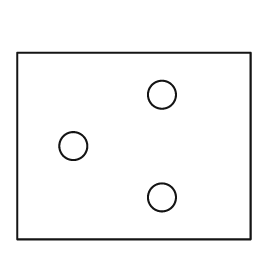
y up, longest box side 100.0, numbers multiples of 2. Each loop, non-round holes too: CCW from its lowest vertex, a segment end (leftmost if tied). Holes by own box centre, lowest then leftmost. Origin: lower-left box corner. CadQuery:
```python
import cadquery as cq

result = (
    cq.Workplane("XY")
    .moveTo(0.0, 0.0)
    .lineTo(100.0, 0.0)
    .lineTo(100.0, 80.0)
    .lineTo(0.0, 80.0)
    .close()
    .moveTo(62.0, 18.0)
    .circle(6.0)
    .moveTo(24.0, 40.0)
    .circle(6.0)
    .moveTo(62.0, 62.0)
    .circle(6.0)
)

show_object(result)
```